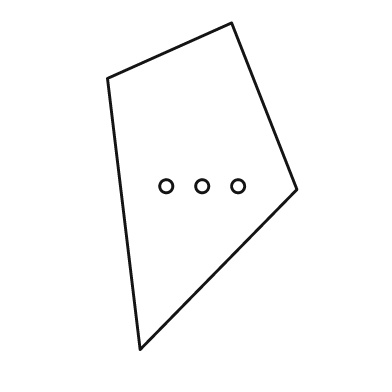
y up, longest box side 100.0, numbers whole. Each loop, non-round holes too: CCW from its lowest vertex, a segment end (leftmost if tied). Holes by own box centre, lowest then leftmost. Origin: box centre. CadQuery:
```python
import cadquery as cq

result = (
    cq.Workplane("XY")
    .moveTo(-19.0, -50.0)
    .lineTo(29.0, -1.0)
    .lineTo(9.0, 50.0)
    .lineTo(-29.0, 33.0)
    .close()
    .moveTo(-11.0, 0.0)
    .circle(2.0)
    .moveTo(0.0, 0.0)
    .circle(2.0)
    .moveTo(11.0, 0.0)
    .circle(2.0)
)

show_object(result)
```